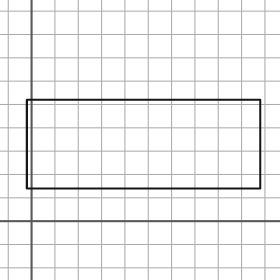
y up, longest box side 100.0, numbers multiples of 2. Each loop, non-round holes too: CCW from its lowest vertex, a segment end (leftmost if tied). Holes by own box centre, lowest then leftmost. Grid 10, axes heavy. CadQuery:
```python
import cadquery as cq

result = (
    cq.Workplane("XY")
    .moveTo(-2.0, 14.0)
    .lineTo(98.0, 14.0)
    .lineTo(98.0, 52.0)
    .lineTo(-2.0, 52.0)
    .close()
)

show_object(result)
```